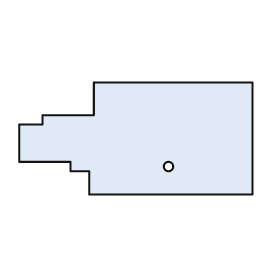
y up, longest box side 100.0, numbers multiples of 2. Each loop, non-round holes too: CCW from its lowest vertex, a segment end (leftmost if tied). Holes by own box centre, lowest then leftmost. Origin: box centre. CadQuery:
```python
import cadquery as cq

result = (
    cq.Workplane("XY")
    .moveTo(-20.0, -24.0)
    .lineTo(50.0, -24.0)
    .lineTo(50.0, 24.0)
    .lineTo(-18.0, 24.0)
    .lineTo(-18.0, 10.0)
    .lineTo(-40.0, 10.0)
    .lineTo(-40.0, 6.0)
    .lineTo(-50.0, 6.0)
    .lineTo(-50.0, -10.0)
    .lineTo(-28.0, -10.0)
    .lineTo(-28.0, -14.0)
    .lineTo(-20.0, -14.0)
    .close()
    .moveTo(14.0, -12.0)
    .circle(2.0)
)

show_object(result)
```